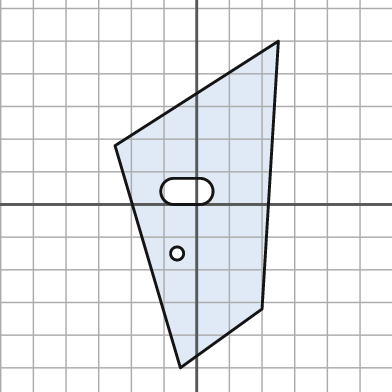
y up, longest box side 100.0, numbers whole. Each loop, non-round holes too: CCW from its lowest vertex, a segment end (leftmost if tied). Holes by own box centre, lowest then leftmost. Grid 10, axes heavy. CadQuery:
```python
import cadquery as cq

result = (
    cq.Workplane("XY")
    .moveTo(-5.0, -50.0)
    .lineTo(20.0, -32.0)
    .lineTo(25.0, 50.0)
    .lineTo(-25.0, 18.0)
    .close()
    .moveTo(-6.0, -15.0)
    .circle(2.0)
    .moveTo(-7.0, 0.0)
    .lineTo(1.0, 0.0)
    .threePointArc((5.0, 4.0), (1.0, 8.0))
    .lineTo(-7.0, 8.0)
    .threePointArc((-11.0, 4.0), (-7.0, 0.0))
    .close()
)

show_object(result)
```